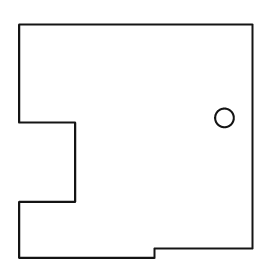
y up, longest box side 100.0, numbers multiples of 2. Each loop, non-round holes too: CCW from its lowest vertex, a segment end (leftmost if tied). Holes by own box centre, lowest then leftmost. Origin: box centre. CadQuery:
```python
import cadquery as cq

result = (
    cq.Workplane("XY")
    .moveTo(-50.0, -50.0)
    .lineTo(8.0, -50.0)
    .lineTo(8.0, -46.0)
    .lineTo(50.0, -46.0)
    .lineTo(50.0, 50.0)
    .lineTo(-50.0, 50.0)
    .lineTo(-50.0, 8.0)
    .lineTo(-26.0, 8.0)
    .lineTo(-26.0, -26.0)
    .lineTo(-50.0, -26.0)
    .close()
    .moveTo(38.0, 10.0)
    .circle(4.0)
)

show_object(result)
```